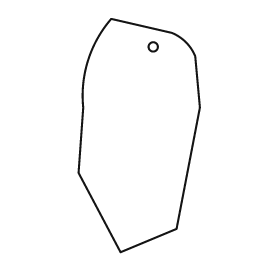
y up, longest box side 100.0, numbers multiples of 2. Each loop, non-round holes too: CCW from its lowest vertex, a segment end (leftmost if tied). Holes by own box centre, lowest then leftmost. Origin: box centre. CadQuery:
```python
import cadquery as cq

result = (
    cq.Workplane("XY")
    .moveTo(-8.0, -50.0)
    .lineTo(16.0, -40.0)
    .lineTo(26.0, 12.0)
    .lineTo(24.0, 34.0)
    .threePointArc((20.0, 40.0), (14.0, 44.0))
    .lineTo(-12.0, 50.0)
    .threePointArc((-22.0, 32.0), (-24.0, 12.0))
    .lineTo(-26.0, -16.0)
    .close()
    .moveTo(6.0, 38.0)
    .circle(2.0)
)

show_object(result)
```